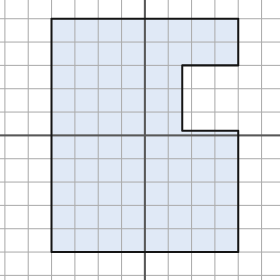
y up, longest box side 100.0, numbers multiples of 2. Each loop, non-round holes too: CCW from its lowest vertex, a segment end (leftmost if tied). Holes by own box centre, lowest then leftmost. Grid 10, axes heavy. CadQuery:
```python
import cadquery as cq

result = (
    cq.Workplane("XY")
    .moveTo(-40.0, -50.0)
    .lineTo(40.0, -50.0)
    .lineTo(40.0, 2.0)
    .lineTo(16.0, 2.0)
    .lineTo(16.0, 30.0)
    .lineTo(40.0, 30.0)
    .lineTo(40.0, 50.0)
    .lineTo(-40.0, 50.0)
    .close()
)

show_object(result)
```